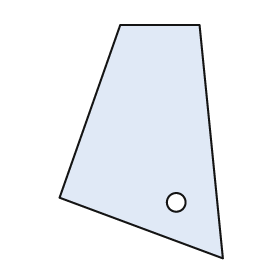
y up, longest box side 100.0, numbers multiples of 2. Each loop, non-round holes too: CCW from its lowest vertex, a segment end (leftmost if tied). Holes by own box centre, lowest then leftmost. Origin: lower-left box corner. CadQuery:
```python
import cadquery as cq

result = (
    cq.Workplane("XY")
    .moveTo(70.0, 0.0)
    .lineTo(60.0, 100.0)
    .lineTo(26.0, 100.0)
    .lineTo(0.0, 26.0)
    .close()
    .moveTo(50.0, 24.0)
    .circle(4.0)
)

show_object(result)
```